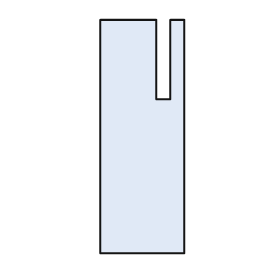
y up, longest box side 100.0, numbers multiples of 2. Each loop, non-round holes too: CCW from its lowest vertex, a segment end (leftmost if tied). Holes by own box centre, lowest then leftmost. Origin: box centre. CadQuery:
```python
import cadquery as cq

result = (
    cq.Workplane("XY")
    .moveTo(-18.0, -50.0)
    .lineTo(18.0, -50.0)
    .lineTo(18.0, 50.0)
    .lineTo(12.0, 50.0)
    .lineTo(12.0, 16.0)
    .lineTo(6.0, 16.0)
    .lineTo(6.0, 50.0)
    .lineTo(-18.0, 50.0)
    .close()
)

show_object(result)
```